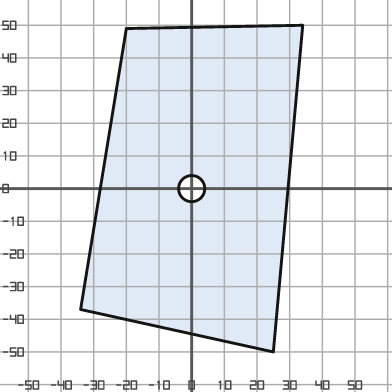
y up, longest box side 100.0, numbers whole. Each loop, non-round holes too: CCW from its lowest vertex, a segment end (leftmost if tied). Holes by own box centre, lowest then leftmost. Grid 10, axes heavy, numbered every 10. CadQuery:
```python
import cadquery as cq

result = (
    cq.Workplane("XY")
    .moveTo(25.0, -50.0)
    .lineTo(34.0, 50.0)
    .lineTo(-20.0, 49.0)
    .lineTo(-34.0, -37.0)
    .close()
    .moveTo(0.0, 0.0)
    .circle(4.0)
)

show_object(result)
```